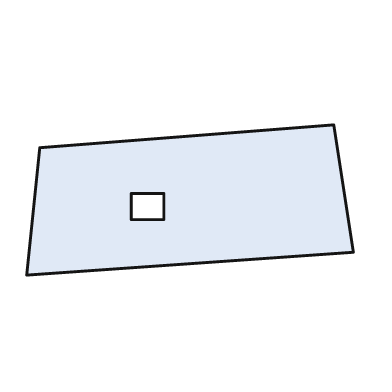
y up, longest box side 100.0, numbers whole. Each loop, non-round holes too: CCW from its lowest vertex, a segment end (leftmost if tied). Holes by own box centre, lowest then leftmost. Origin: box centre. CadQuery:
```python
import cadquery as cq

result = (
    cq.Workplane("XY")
    .moveTo(-50.0, -23.0)
    .lineTo(50.0, -16.0)
    .lineTo(44.0, 23.0)
    .lineTo(-46.0, 16.0)
    .close()
    .moveTo(-18.0, -6.0)
    .lineTo(-8.0, -6.0)
    .lineTo(-8.0, 2.0)
    .lineTo(-18.0, 2.0)
    .close()
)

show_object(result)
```